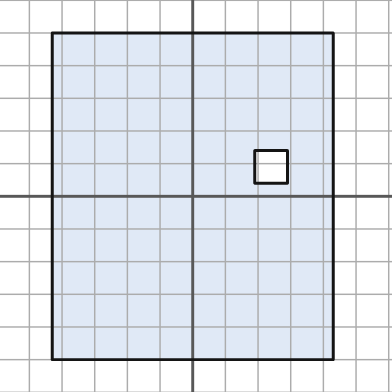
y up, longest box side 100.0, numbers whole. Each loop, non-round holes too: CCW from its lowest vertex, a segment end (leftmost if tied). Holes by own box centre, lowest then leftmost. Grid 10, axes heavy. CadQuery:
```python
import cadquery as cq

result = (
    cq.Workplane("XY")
    .moveTo(-43.0, -50.0)
    .lineTo(43.0, -50.0)
    .lineTo(43.0, 50.0)
    .lineTo(-43.0, 50.0)
    .close()
    .moveTo(19.0, 4.0)
    .lineTo(29.0, 4.0)
    .lineTo(29.0, 14.0)
    .lineTo(19.0, 14.0)
    .close()
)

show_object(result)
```